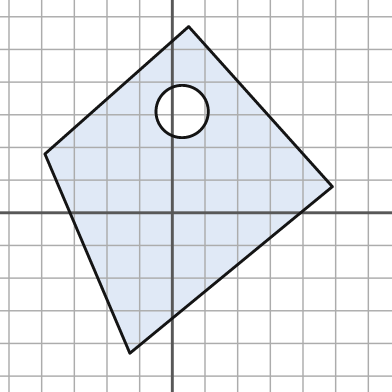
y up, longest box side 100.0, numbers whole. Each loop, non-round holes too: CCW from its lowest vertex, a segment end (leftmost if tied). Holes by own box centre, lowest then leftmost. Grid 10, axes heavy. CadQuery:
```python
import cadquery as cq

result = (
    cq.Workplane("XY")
    .moveTo(-13.0, -43.0)
    .lineTo(49.0, 8.0)
    .lineTo(5.0, 57.0)
    .lineTo(-39.0, 18.0)
    .close()
    .moveTo(3.0, 31.0)
    .circle(8.0)
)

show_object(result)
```